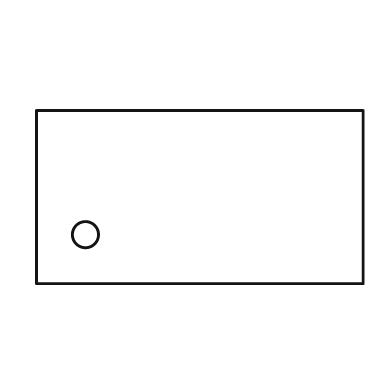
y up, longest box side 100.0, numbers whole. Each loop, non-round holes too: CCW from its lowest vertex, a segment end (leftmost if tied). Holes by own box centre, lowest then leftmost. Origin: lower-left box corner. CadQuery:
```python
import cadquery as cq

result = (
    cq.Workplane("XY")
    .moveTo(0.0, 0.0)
    .lineTo(100.0, 0.0)
    .lineTo(100.0, 53.0)
    .lineTo(0.0, 53.0)
    .close()
    .moveTo(15.0, 15.0)
    .circle(4.0)
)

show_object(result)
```